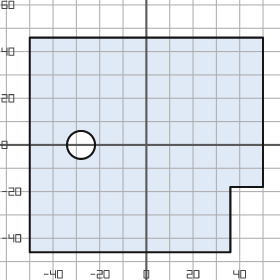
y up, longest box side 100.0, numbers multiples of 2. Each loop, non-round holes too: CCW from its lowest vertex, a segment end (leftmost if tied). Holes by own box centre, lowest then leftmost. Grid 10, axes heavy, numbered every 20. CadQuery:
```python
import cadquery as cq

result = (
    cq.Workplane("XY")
    .moveTo(-50.0, -46.0)
    .lineTo(36.0, -46.0)
    .lineTo(36.0, -18.0)
    .lineTo(50.0, -18.0)
    .lineTo(50.0, 46.0)
    .lineTo(-50.0, 46.0)
    .close()
    .moveTo(-28.0, 0.0)
    .circle(6.0)
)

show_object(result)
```